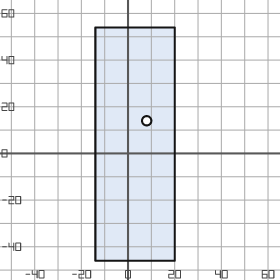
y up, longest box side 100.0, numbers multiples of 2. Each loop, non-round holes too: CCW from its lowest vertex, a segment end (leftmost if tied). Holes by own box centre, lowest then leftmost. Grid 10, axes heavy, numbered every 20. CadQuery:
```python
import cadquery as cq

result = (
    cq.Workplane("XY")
    .moveTo(-14.0, -46.0)
    .lineTo(20.0, -46.0)
    .lineTo(20.0, 54.0)
    .lineTo(-14.0, 54.0)
    .close()
    .moveTo(8.0, 14.0)
    .circle(2.0)
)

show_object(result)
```